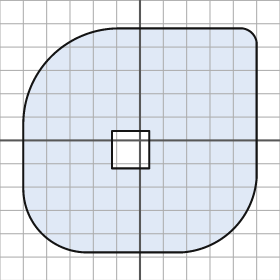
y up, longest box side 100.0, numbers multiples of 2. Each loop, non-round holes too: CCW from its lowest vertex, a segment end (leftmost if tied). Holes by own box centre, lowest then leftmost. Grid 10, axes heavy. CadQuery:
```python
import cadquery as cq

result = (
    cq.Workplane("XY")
    .moveTo(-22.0, -48.0)
    .lineTo(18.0, -48.0)
    .threePointArc((40.0, -38.0), (50.0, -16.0))
    .lineTo(50.0, 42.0)
    .threePointArc((48.0, 46.0), (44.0, 48.0))
    .lineTo(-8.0, 48.0)
    .threePointArc((-38.0, 36.0), (-50.0, 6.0))
    .lineTo(-50.0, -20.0)
    .threePointArc((-42.0, -40.0), (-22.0, -48.0))
    .close()
    .moveTo(-12.0, -12.0)
    .lineTo(4.0, -12.0)
    .lineTo(4.0, 4.0)
    .lineTo(-12.0, 4.0)
    .close()
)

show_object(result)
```